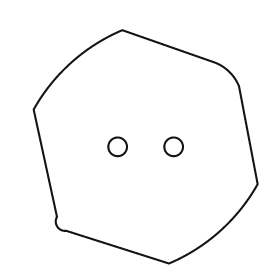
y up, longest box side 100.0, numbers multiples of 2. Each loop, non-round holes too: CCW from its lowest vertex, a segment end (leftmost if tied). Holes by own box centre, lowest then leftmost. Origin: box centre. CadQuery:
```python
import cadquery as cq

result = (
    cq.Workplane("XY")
    .moveTo(10.0, -50.0)
    .threePointArc((32.0, -36.0), (48.0, -16.0))
    .lineTo(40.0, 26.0)
    .threePointArc((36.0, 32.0), (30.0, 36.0))
    .lineTo(-10.0, 50.0)
    .threePointArc((-32.0, 36.0), (-48.0, 16.0))
    .lineTo(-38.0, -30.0)
    .threePointArc((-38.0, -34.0), (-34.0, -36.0))
    .close()
    .moveTo(-12.0, 0.0)
    .circle(4.0)
    .moveTo(12.0, 0.0)
    .circle(4.0)
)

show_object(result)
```